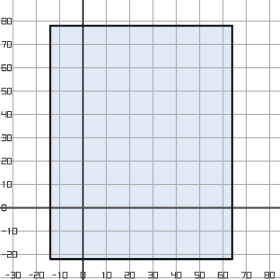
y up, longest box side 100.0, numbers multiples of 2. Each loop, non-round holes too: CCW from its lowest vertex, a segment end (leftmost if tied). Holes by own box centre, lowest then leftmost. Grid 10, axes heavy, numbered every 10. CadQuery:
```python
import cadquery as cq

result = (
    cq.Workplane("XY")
    .moveTo(-14.0, -22.0)
    .lineTo(64.0, -22.0)
    .lineTo(64.0, 78.0)
    .lineTo(-14.0, 78.0)
    .close()
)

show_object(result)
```